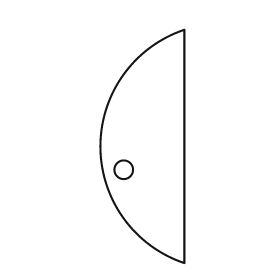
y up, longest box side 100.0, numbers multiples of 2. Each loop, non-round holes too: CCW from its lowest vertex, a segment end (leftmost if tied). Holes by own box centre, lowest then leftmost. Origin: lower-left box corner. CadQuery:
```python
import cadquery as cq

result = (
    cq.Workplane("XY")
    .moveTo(36.0, 0.0)
    .lineTo(36.0, 100.0)
    .threePointArc((0.0, 50.0), (36.0, 0.0))
    .close()
    .moveTo(10.0, 40.0)
    .circle(4.0)
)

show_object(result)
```